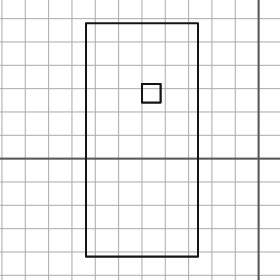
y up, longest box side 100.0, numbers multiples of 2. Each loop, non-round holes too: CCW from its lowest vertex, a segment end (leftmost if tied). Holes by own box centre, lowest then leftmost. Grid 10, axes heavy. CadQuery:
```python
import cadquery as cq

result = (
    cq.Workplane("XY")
    .moveTo(-74.0, -42.0)
    .lineTo(-26.0, -42.0)
    .lineTo(-26.0, 58.0)
    .lineTo(-74.0, 58.0)
    .close()
    .moveTo(-50.0, 24.0)
    .lineTo(-42.0, 24.0)
    .lineTo(-42.0, 32.0)
    .lineTo(-50.0, 32.0)
    .close()
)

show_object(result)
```